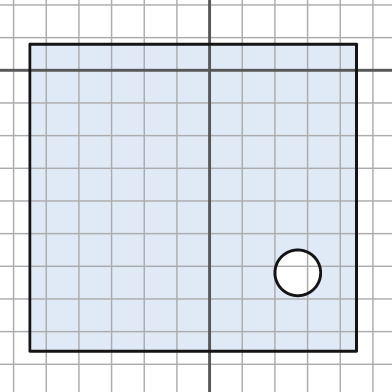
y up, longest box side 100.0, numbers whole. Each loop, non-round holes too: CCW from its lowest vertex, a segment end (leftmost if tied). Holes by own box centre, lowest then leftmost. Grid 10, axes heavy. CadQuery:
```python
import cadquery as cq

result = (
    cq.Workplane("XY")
    .moveTo(-55.0, -86.0)
    .lineTo(45.0, -86.0)
    .lineTo(45.0, 8.0)
    .lineTo(-55.0, 8.0)
    .close()
    .moveTo(27.0, -62.0)
    .circle(7.0)
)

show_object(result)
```